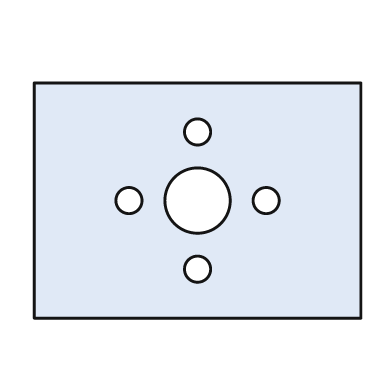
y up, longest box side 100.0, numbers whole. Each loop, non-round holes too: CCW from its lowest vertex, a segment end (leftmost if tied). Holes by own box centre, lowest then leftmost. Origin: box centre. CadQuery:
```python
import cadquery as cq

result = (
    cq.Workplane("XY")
    .moveTo(-50.0, -36.0)
    .lineTo(50.0, -36.0)
    .lineTo(50.0, 36.0)
    .lineTo(-50.0, 36.0)
    .close()
    .moveTo(0.0, -21.0)
    .circle(4.0)
    .moveTo(-21.0, 0.0)
    .circle(4.0)
    .moveTo(0.0, 0.0)
    .circle(10.0)
    .moveTo(21.0, 0.0)
    .circle(4.0)
    .moveTo(0.0, 21.0)
    .circle(4.0)
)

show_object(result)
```